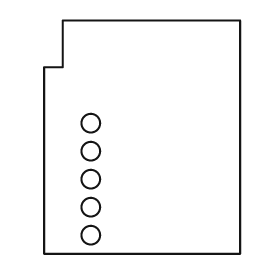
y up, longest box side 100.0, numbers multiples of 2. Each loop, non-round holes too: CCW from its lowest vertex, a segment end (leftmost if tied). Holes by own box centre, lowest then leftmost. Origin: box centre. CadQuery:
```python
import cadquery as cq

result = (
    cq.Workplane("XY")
    .moveTo(-42.0, -50.0)
    .lineTo(42.0, -50.0)
    .lineTo(42.0, 50.0)
    .lineTo(-34.0, 50.0)
    .lineTo(-34.0, 30.0)
    .lineTo(-42.0, 30.0)
    .close()
    .moveTo(-22.0, -42.0)
    .circle(4.0)
    .moveTo(-22.0, -30.0)
    .circle(4.0)
    .moveTo(-22.0, -18.0)
    .circle(4.0)
    .moveTo(-22.0, -6.0)
    .circle(4.0)
    .moveTo(-22.0, 6.0)
    .circle(4.0)
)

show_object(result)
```